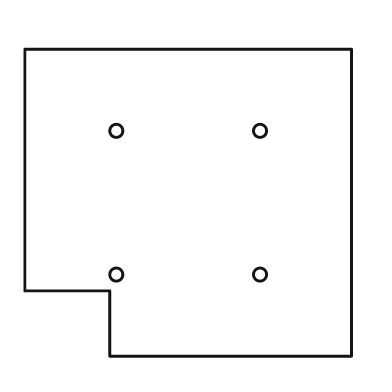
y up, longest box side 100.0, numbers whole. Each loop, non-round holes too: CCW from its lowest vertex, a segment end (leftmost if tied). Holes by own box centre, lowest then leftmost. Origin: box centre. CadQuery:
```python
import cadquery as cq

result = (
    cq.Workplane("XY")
    .moveTo(-24.0, -47.0)
    .lineTo(50.0, -47.0)
    .lineTo(50.0, 47.0)
    .lineTo(-50.0, 47.0)
    .lineTo(-50.0, -27.0)
    .lineTo(-24.0, -27.0)
    .close()
    .moveTo(-22.0, -22.0)
    .circle(2.0)
    .moveTo(22.0, -22.0)
    .circle(2.0)
    .moveTo(-22.0, 22.0)
    .circle(2.0)
    .moveTo(22.0, 22.0)
    .circle(2.0)
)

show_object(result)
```